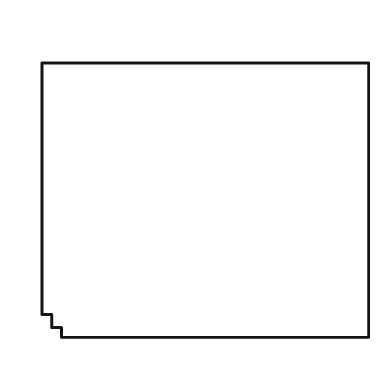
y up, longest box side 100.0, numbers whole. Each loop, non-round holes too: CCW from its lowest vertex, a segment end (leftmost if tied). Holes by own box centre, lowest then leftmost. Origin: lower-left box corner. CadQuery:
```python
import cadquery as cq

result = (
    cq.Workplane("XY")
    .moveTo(6.0, 0.0)
    .lineTo(100.0, 0.0)
    .lineTo(100.0, 84.0)
    .lineTo(0.0, 84.0)
    .lineTo(0.0, 7.0)
    .lineTo(3.0, 7.0)
    .lineTo(3.0, 3.0)
    .lineTo(6.0, 3.0)
    .close()
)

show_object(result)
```